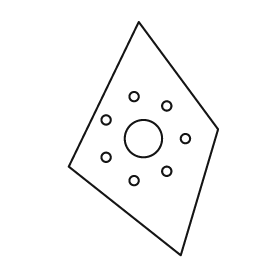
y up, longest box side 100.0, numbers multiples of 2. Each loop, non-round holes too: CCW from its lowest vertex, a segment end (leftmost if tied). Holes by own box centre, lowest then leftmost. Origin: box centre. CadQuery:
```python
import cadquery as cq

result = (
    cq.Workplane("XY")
    .moveTo(16.0, -50.0)
    .lineTo(32.0, 4.0)
    .lineTo(-2.0, 50.0)
    .lineTo(-32.0, -12.0)
    .close()
    .moveTo(-4.0, -18.0)
    .circle(2.0)
    .moveTo(10.0, -14.0)
    .circle(2.0)
    .moveTo(-16.0, -8.0)
    .circle(2.0)
    .moveTo(0.0, 0.0)
    .circle(8.0)
    .moveTo(18.0, 0.0)
    .circle(2.0)
    .moveTo(-16.0, 8.0)
    .circle(2.0)
    .moveTo(10.0, 14.0)
    .circle(2.0)
    .moveTo(-4.0, 18.0)
    .circle(2.0)
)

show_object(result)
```